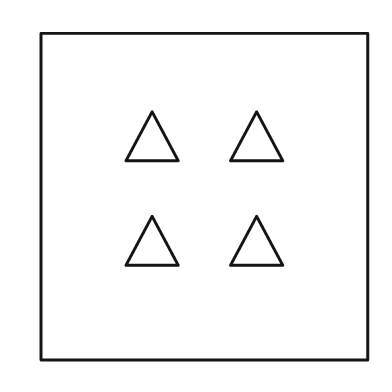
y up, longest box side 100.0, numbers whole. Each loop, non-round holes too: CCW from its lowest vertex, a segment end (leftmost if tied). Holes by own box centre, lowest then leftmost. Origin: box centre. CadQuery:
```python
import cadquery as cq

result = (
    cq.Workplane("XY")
    .moveTo(-50.0, -50.0)
    .lineTo(50.0, -50.0)
    .lineTo(50.0, 50.0)
    .lineTo(-50.0, 50.0)
    .close()
    .moveTo(-24.0, -21.0)
    .lineTo(-8.0, -21.0)
    .lineTo(-16.0, -6.0)
    .close()
    .moveTo(8.0, -21.0)
    .lineTo(24.0, -21.0)
    .lineTo(16.0, -6.0)
    .close()
    .moveTo(-24.0, 11.0)
    .lineTo(-8.0, 11.0)
    .lineTo(-16.0, 26.0)
    .close()
    .moveTo(8.0, 11.0)
    .lineTo(24.0, 11.0)
    .lineTo(16.0, 26.0)
    .close()
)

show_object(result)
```